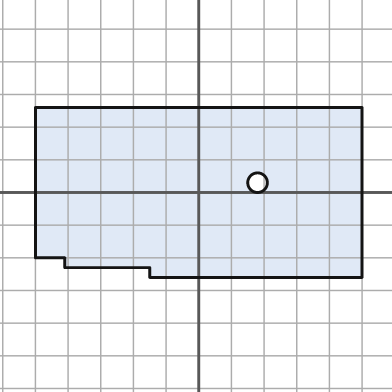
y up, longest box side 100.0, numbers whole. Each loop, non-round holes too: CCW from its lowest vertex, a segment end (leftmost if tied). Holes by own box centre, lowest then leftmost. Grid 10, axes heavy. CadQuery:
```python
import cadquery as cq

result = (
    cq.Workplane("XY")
    .moveTo(-15.0, -26.0)
    .lineTo(50.0, -26.0)
    .lineTo(50.0, 26.0)
    .lineTo(-50.0, 26.0)
    .lineTo(-50.0, -20.0)
    .lineTo(-41.0, -20.0)
    .lineTo(-41.0, -23.0)
    .lineTo(-15.0, -23.0)
    .close()
    .moveTo(18.0, 3.0)
    .circle(3.0)
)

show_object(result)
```